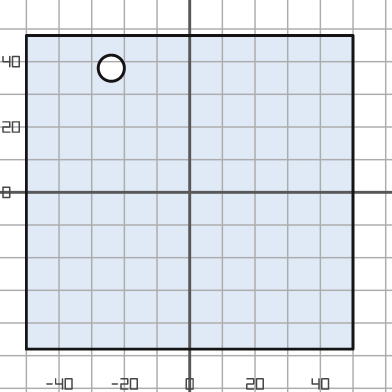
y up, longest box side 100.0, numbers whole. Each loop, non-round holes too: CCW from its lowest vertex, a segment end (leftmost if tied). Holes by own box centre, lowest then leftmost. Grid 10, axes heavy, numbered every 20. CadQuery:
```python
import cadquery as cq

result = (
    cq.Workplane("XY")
    .moveTo(-50.0, -48.0)
    .lineTo(50.0, -48.0)
    .lineTo(50.0, 48.0)
    .lineTo(-50.0, 48.0)
    .close()
    .moveTo(-24.0, 38.0)
    .circle(4.0)
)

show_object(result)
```